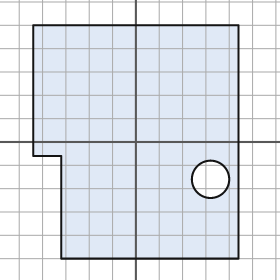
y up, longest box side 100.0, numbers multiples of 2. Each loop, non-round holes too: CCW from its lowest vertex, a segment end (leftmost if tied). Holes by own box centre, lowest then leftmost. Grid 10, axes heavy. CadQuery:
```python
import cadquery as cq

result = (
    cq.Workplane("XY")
    .moveTo(-32.0, -50.0)
    .lineTo(44.0, -50.0)
    .lineTo(44.0, 50.0)
    .lineTo(-44.0, 50.0)
    .lineTo(-44.0, -6.0)
    .lineTo(-32.0, -6.0)
    .close()
    .moveTo(32.0, -16.0)
    .circle(8.0)
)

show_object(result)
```